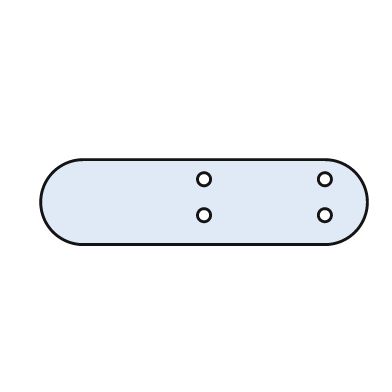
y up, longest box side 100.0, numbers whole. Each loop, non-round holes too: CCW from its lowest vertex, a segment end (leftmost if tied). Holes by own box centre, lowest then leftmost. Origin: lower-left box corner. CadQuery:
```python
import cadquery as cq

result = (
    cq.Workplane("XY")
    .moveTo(13.0, 0.0)
    .lineTo(87.0, 0.0)
    .threePointArc((100.0, 13.0), (87.0, 26.0))
    .lineTo(13.0, 26.0)
    .threePointArc((0.0, 13.0), (13.0, 0.0))
    .close()
    .moveTo(50.0, 9.0)
    .circle(2.0)
    .moveTo(87.0, 9.0)
    .circle(2.0)
    .moveTo(50.0, 20.0)
    .circle(2.0)
    .moveTo(87.0, 20.0)
    .circle(2.0)
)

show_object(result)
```